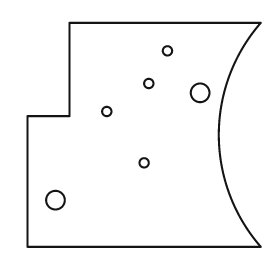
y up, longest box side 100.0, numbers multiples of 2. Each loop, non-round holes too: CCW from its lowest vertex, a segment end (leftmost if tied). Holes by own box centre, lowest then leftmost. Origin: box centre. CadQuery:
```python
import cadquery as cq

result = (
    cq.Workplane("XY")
    .moveTo(-50.0, -48.0)
    .lineTo(50.0, -48.0)
    .threePointArc((32.0, 0.0), (50.0, 48.0))
    .lineTo(-32.0, 48.0)
    .lineTo(-32.0, 8.0)
    .lineTo(-50.0, 8.0)
    .close()
    .moveTo(-38.0, -28.0)
    .circle(4.0)
    .moveTo(0.0, -12.0)
    .circle(2.0)
    .moveTo(-16.0, 10.0)
    .circle(2.0)
    .moveTo(24.0, 18.0)
    .circle(4.0)
    .moveTo(2.0, 22.0)
    .circle(2.0)
    .moveTo(10.0, 36.0)
    .circle(2.0)
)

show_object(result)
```